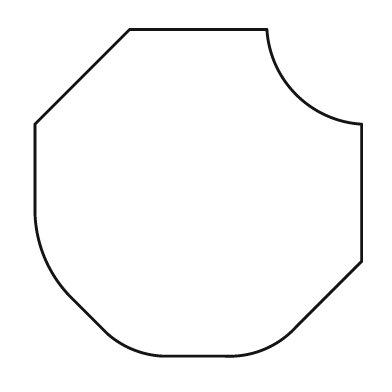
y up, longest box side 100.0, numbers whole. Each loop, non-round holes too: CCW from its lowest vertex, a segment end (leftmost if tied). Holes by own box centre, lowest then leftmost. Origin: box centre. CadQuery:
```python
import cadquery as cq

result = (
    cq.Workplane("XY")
    .moveTo(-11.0, -50.0)
    .lineTo(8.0, -50.0)
    .threePointArc((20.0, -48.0), (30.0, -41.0))
    .lineTo(50.0, -21.0)
    .lineTo(50.0, 21.0)
    .threePointArc((30.0, 30.0), (21.0, 50.0))
    .lineTo(-21.0, 50.0)
    .lineTo(-50.0, 21.0)
    .lineTo(-50.0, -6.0)
    .threePointArc((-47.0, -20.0), (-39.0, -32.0))
    .lineTo(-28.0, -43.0)
    .threePointArc((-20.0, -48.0), (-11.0, -50.0))
    .close()
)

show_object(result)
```